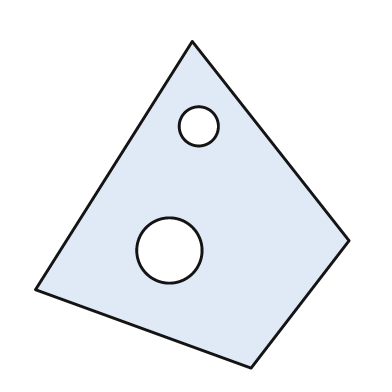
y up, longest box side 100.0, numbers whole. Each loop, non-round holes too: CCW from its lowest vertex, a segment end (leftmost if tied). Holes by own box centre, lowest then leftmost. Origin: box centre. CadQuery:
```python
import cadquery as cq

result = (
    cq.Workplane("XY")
    .moveTo(18.0, -50.0)
    .lineTo(48.0, -11.0)
    .lineTo(0.0, 50.0)
    .lineTo(-48.0, -26.0)
    .close()
    .moveTo(-7.0, -14.0)
    .circle(10.0)
    .moveTo(2.0, 24.0)
    .circle(6.0)
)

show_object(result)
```